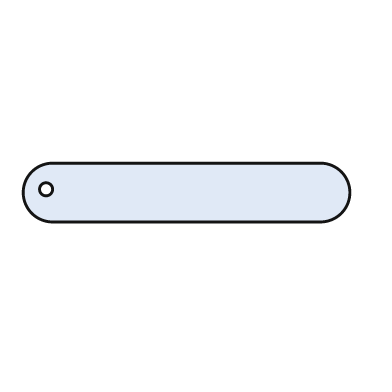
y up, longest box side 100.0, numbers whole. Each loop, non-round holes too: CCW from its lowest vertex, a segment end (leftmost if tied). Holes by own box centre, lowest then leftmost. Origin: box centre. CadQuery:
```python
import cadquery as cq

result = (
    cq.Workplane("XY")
    .moveTo(-41.0, -9.0)
    .lineTo(41.0, -9.0)
    .threePointArc((50.0, 0.0), (41.0, 9.0))
    .lineTo(-41.0, 9.0)
    .threePointArc((-50.0, 0.0), (-41.0, -9.0))
    .close()
    .moveTo(-43.0, 1.0)
    .circle(2.0)
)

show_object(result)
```